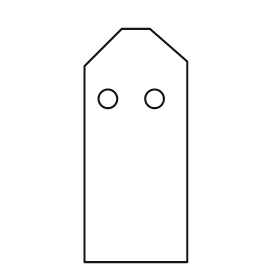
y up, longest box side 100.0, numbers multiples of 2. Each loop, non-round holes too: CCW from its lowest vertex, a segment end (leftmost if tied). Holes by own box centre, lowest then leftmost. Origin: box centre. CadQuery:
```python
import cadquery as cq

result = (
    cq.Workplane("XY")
    .moveTo(-22.0, -50.0)
    .lineTo(22.0, -50.0)
    .lineTo(22.0, 36.0)
    .lineTo(6.0, 50.0)
    .lineTo(-6.0, 50.0)
    .lineTo(-22.0, 34.0)
    .close()
    .moveTo(-12.0, 20.0)
    .circle(4.0)
    .moveTo(8.0, 20.0)
    .circle(4.0)
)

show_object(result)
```